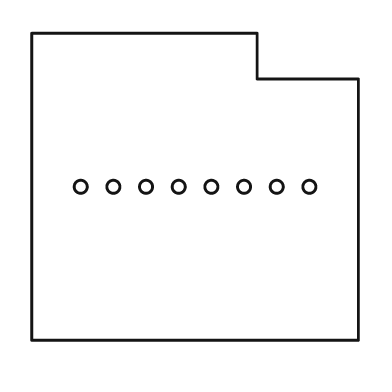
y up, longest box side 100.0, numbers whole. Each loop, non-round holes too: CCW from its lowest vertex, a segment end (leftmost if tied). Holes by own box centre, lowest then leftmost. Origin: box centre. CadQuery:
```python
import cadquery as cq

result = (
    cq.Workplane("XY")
    .moveTo(-50.0, -47.0)
    .lineTo(50.0, -47.0)
    .lineTo(50.0, 33.0)
    .lineTo(19.0, 33.0)
    .lineTo(19.0, 47.0)
    .lineTo(-50.0, 47.0)
    .close()
    .moveTo(-35.0, 0.0)
    .circle(2.0)
    .moveTo(-25.0, 0.0)
    .circle(2.0)
    .moveTo(-15.0, 0.0)
    .circle(2.0)
    .moveTo(-5.0, 0.0)
    .circle(2.0)
    .moveTo(5.0, 0.0)
    .circle(2.0)
    .moveTo(15.0, 0.0)
    .circle(2.0)
    .moveTo(25.0, 0.0)
    .circle(2.0)
    .moveTo(35.0, 0.0)
    .circle(2.0)
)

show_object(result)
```